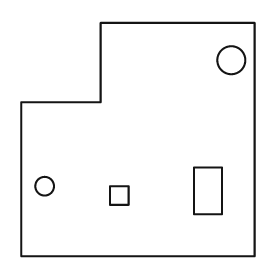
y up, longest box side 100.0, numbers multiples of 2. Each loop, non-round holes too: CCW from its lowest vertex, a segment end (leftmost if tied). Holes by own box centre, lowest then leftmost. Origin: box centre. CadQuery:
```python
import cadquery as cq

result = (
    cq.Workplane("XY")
    .moveTo(-50.0, -50.0)
    .lineTo(50.0, -50.0)
    .lineTo(50.0, 50.0)
    .lineTo(-16.0, 50.0)
    .lineTo(-16.0, 16.0)
    .lineTo(-50.0, 16.0)
    .close()
    .moveTo(-12.0, -28.0)
    .lineTo(-4.0, -28.0)
    .lineTo(-4.0, -20.0)
    .lineTo(-12.0, -20.0)
    .close()
    .moveTo(24.0, -32.0)
    .lineTo(36.0, -32.0)
    .lineTo(36.0, -12.0)
    .lineTo(24.0, -12.0)
    .close()
    .moveTo(-40.0, -20.0)
    .circle(4.0)
    .moveTo(40.0, 34.0)
    .circle(6.0)
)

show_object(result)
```